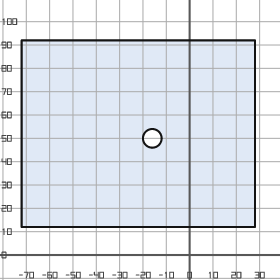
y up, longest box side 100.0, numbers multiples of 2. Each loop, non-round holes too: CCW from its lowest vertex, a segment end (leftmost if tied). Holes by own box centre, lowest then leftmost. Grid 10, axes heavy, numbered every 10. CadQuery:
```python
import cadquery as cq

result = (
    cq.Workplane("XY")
    .moveTo(-72.0, 12.0)
    .lineTo(28.0, 12.0)
    .lineTo(28.0, 92.0)
    .lineTo(-72.0, 92.0)
    .close()
    .moveTo(-16.0, 50.0)
    .circle(4.0)
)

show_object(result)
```